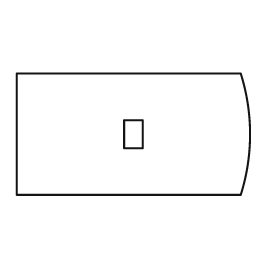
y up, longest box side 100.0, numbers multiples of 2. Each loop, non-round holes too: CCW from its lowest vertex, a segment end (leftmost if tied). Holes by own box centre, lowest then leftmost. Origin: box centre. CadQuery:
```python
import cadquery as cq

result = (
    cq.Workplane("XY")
    .moveTo(-50.0, -26.0)
    .lineTo(46.0, -26.0)
    .threePointArc((50.0, 0.0), (46.0, 26.0))
    .lineTo(-50.0, 26.0)
    .close()
    .moveTo(-4.0, -6.0)
    .lineTo(4.0, -6.0)
    .lineTo(4.0, 6.0)
    .lineTo(-4.0, 6.0)
    .close()
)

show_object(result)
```